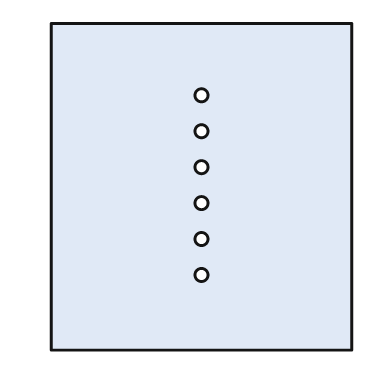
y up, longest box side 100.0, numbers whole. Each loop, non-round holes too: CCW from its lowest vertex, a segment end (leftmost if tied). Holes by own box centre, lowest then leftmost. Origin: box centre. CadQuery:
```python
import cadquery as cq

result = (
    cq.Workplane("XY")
    .moveTo(-46.0, -50.0)
    .lineTo(46.0, -50.0)
    .lineTo(46.0, 50.0)
    .lineTo(-46.0, 50.0)
    .close()
    .moveTo(0.0, -27.0)
    .circle(2.0)
    .moveTo(0.0, -16.0)
    .circle(2.0)
    .moveTo(0.0, -5.0)
    .circle(2.0)
    .moveTo(0.0, 6.0)
    .circle(2.0)
    .moveTo(0.0, 17.0)
    .circle(2.0)
    .moveTo(0.0, 28.0)
    .circle(2.0)
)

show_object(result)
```